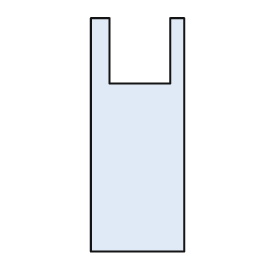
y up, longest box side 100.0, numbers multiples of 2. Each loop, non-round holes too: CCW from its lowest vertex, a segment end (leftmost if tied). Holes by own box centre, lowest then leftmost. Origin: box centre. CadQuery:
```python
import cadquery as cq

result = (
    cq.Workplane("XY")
    .moveTo(-20.0, -50.0)
    .lineTo(20.0, -50.0)
    .lineTo(20.0, 50.0)
    .lineTo(14.0, 50.0)
    .lineTo(14.0, 22.0)
    .lineTo(-12.0, 22.0)
    .lineTo(-12.0, 50.0)
    .lineTo(-20.0, 50.0)
    .close()
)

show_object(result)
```